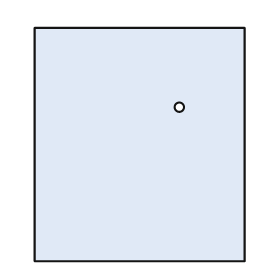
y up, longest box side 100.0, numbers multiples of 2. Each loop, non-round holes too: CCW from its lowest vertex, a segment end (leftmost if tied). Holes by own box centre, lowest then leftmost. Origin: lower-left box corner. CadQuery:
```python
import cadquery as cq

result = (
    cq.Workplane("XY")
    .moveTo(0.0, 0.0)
    .lineTo(90.0, 0.0)
    .lineTo(90.0, 100.0)
    .lineTo(0.0, 100.0)
    .close()
    .moveTo(62.0, 66.0)
    .circle(2.0)
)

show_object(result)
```